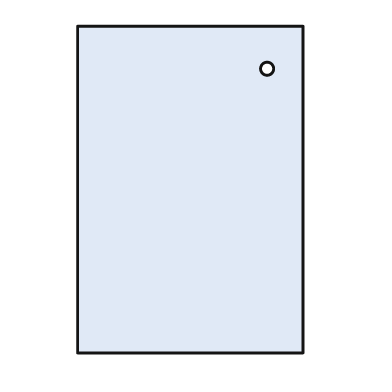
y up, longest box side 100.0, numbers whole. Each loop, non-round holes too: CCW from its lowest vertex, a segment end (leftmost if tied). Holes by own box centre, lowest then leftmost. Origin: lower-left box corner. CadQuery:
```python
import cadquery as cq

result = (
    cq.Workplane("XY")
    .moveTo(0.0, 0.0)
    .lineTo(69.0, 0.0)
    .lineTo(69.0, 100.0)
    .lineTo(0.0, 100.0)
    .close()
    .moveTo(58.0, 87.0)
    .circle(2.0)
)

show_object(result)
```